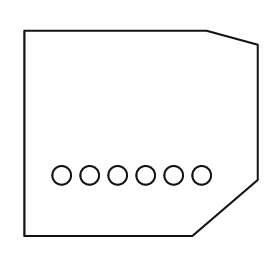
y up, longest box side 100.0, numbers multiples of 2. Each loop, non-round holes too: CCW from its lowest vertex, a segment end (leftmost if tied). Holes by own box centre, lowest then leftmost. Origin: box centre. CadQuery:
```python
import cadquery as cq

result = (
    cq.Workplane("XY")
    .moveTo(-50.0, -44.0)
    .lineTo(22.0, -44.0)
    .lineTo(50.0, -20.0)
    .lineTo(50.0, 38.0)
    .lineTo(28.0, 44.0)
    .lineTo(-50.0, 44.0)
    .close()
    .moveTo(-34.0, -18.0)
    .circle(4.0)
    .moveTo(-22.0, -18.0)
    .circle(4.0)
    .moveTo(-10.0, -18.0)
    .circle(4.0)
    .moveTo(2.0, -18.0)
    .circle(4.0)
    .moveTo(14.0, -18.0)
    .circle(4.0)
    .moveTo(26.0, -18.0)
    .circle(4.0)
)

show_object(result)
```